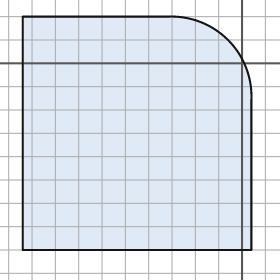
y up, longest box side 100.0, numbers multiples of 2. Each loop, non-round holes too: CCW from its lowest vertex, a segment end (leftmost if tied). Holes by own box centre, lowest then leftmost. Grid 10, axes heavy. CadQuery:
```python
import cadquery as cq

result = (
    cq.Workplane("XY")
    .moveTo(-94.0, -80.0)
    .lineTo(4.0, -80.0)
    .lineTo(4.0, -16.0)
    .threePointArc((-6.0, 10.0), (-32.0, 20.0))
    .lineTo(-94.0, 20.0)
    .close()
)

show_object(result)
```